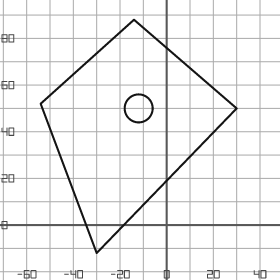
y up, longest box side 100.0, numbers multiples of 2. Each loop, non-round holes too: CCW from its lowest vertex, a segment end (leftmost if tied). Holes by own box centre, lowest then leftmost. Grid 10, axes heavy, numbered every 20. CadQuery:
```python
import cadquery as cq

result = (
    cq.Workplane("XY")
    .moveTo(-30.0, -12.0)
    .lineTo(30.0, 50.0)
    .lineTo(-14.0, 88.0)
    .lineTo(-54.0, 52.0)
    .close()
    .moveTo(-12.0, 50.0)
    .circle(6.0)
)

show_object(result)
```